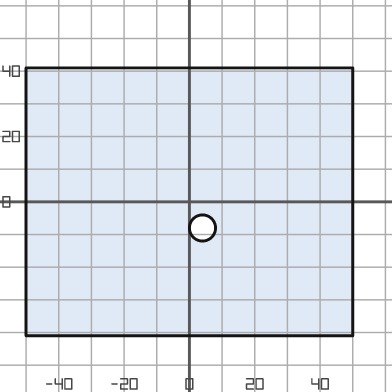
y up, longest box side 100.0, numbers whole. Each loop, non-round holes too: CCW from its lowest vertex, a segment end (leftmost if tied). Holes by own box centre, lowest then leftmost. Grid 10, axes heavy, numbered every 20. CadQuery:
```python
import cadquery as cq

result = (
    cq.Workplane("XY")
    .moveTo(-50.0, -41.0)
    .lineTo(50.0, -41.0)
    .lineTo(50.0, 41.0)
    .lineTo(-50.0, 41.0)
    .close()
    .moveTo(4.0, -8.0)
    .circle(4.0)
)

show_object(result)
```